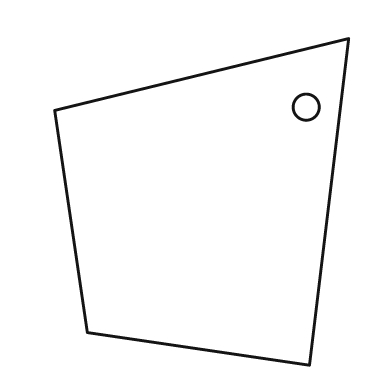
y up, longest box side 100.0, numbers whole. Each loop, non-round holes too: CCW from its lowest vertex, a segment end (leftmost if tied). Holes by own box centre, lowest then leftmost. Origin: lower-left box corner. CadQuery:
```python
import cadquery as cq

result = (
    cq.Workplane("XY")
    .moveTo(78.0, 0.0)
    .lineTo(90.0, 100.0)
    .lineTo(0.0, 78.0)
    .lineTo(10.0, 10.0)
    .close()
    .moveTo(77.0, 79.0)
    .circle(4.0)
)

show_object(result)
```